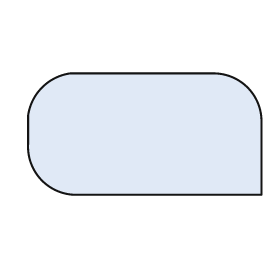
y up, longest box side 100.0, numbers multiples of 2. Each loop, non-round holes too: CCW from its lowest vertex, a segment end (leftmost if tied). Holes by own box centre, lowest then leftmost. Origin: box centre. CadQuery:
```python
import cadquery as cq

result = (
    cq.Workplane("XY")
    .moveTo(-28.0, -26.0)
    .lineTo(50.0, -26.0)
    .lineTo(50.0, 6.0)
    .threePointArc((44.0, 20.0), (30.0, 26.0))
    .lineTo(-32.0, 26.0)
    .threePointArc((-44.0, 20.0), (-50.0, 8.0))
    .lineTo(-50.0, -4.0)
    .threePointArc((-44.0, -20.0), (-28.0, -26.0))
    .close()
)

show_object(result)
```